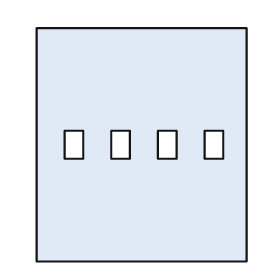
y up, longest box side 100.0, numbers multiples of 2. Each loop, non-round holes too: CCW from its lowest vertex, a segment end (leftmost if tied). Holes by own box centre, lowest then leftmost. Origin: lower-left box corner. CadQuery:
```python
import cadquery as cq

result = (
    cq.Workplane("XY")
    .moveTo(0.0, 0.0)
    .lineTo(90.0, 0.0)
    .lineTo(90.0, 100.0)
    .lineTo(0.0, 100.0)
    .close()
    .moveTo(12.0, 44.0)
    .lineTo(20.0, 44.0)
    .lineTo(20.0, 56.0)
    .lineTo(12.0, 56.0)
    .close()
    .moveTo(32.0, 44.0)
    .lineTo(40.0, 44.0)
    .lineTo(40.0, 56.0)
    .lineTo(32.0, 56.0)
    .close()
    .moveTo(52.0, 44.0)
    .lineTo(60.0, 44.0)
    .lineTo(60.0, 56.0)
    .lineTo(52.0, 56.0)
    .close()
    .moveTo(72.0, 44.0)
    .lineTo(80.0, 44.0)
    .lineTo(80.0, 56.0)
    .lineTo(72.0, 56.0)
    .close()
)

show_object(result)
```